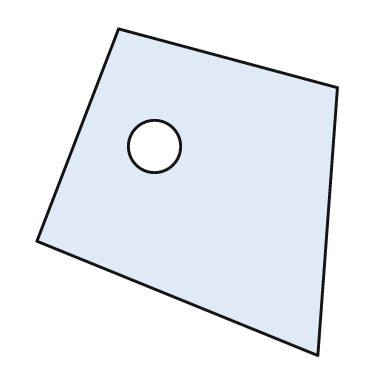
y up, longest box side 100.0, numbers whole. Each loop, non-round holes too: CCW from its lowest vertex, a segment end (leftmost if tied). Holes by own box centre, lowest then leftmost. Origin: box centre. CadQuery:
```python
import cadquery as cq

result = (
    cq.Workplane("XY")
    .moveTo(40.0, -50.0)
    .lineTo(46.0, 32.0)
    .lineTo(-21.0, 50.0)
    .lineTo(-46.0, -15.0)
    .close()
    .moveTo(-10.0, 14.0)
    .circle(8.0)
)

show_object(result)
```